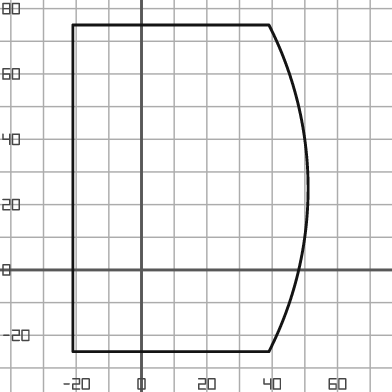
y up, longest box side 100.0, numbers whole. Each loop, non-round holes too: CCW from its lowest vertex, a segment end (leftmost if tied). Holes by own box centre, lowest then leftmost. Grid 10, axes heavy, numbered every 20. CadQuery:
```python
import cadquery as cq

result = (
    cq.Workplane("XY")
    .moveTo(-21.0, -25.0)
    .lineTo(39.0, -25.0)
    .threePointArc((51.0, 25.0), (39.0, 75.0))
    .lineTo(-21.0, 75.0)
    .close()
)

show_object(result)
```